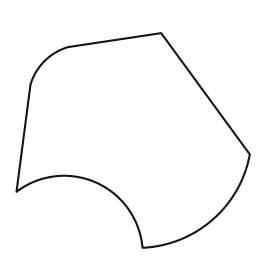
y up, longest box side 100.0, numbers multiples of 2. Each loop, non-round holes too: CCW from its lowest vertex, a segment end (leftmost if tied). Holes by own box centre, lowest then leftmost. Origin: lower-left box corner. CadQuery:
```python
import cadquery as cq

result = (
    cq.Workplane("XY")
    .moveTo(54.0, 0.0)
    .threePointArc((84.0, 12.0), (100.0, 40.0))
    .lineTo(62.0, 92.0)
    .lineTo(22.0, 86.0)
    .threePointArc((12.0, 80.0), (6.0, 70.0))
    .lineTo(0.0, 24.0)
    .threePointArc((34.0, 28.0), (54.0, 0.0))
    .close()
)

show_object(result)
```